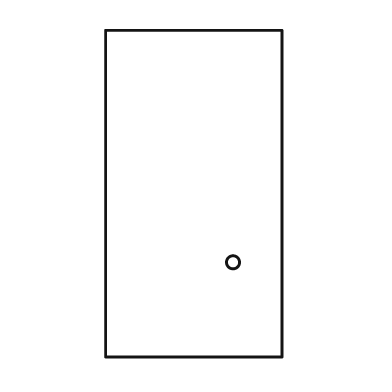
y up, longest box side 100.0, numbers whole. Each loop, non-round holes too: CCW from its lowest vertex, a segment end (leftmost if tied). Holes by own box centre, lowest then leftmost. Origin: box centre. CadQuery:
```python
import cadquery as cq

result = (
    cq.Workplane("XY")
    .moveTo(-27.0, -50.0)
    .lineTo(27.0, -50.0)
    .lineTo(27.0, 50.0)
    .lineTo(-27.0, 50.0)
    .close()
    .moveTo(12.0, -21.0)
    .circle(2.0)
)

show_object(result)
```